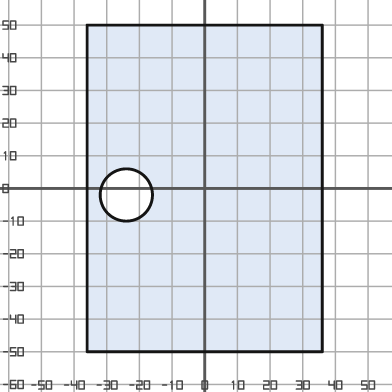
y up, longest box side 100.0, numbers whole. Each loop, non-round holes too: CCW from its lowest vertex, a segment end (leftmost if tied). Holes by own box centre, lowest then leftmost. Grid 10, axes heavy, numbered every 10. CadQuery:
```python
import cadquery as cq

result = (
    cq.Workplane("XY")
    .moveTo(-36.0, -50.0)
    .lineTo(36.0, -50.0)
    .lineTo(36.0, 50.0)
    .lineTo(-36.0, 50.0)
    .close()
    .moveTo(-24.0, -2.0)
    .circle(8.0)
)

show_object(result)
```